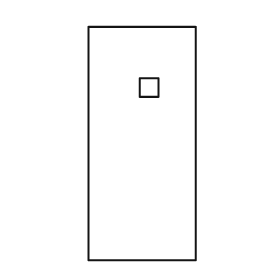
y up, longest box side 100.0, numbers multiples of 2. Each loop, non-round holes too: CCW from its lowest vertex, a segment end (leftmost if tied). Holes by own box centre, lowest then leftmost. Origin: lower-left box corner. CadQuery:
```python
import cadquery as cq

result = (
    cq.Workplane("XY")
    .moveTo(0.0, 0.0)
    .lineTo(46.0, 0.0)
    .lineTo(46.0, 100.0)
    .lineTo(0.0, 100.0)
    .close()
    .moveTo(22.0, 70.0)
    .lineTo(30.0, 70.0)
    .lineTo(30.0, 78.0)
    .lineTo(22.0, 78.0)
    .close()
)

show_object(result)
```